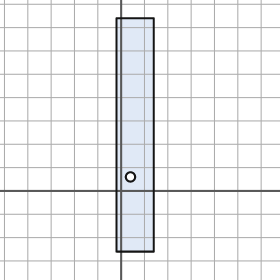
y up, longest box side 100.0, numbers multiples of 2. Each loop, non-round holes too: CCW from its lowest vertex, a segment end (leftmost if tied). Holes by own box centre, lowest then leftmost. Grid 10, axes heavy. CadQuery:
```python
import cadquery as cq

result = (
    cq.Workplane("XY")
    .moveTo(-2.0, -26.0)
    .lineTo(14.0, -26.0)
    .lineTo(14.0, 74.0)
    .lineTo(-2.0, 74.0)
    .close()
    .moveTo(4.0, 6.0)
    .circle(2.0)
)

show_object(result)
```